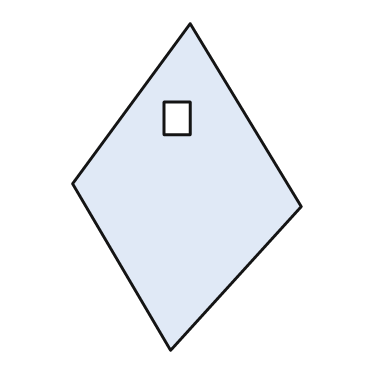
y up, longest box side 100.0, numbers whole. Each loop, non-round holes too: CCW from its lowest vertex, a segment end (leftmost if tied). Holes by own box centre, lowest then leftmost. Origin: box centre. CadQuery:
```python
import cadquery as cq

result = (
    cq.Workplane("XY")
    .moveTo(-5.0, -50.0)
    .lineTo(35.0, -6.0)
    .lineTo(1.0, 50.0)
    .lineTo(-35.0, 1.0)
    .close()
    .moveTo(-7.0, 16.0)
    .lineTo(1.0, 16.0)
    .lineTo(1.0, 26.0)
    .lineTo(-7.0, 26.0)
    .close()
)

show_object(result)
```